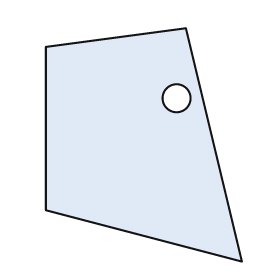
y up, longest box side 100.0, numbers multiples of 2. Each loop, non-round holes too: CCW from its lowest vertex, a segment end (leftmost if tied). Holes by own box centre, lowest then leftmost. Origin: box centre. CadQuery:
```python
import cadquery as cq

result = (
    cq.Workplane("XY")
    .moveTo(42.0, -50.0)
    .lineTo(18.0, 50.0)
    .lineTo(-42.0, 42.0)
    .lineTo(-42.0, -28.0)
    .close()
    .moveTo(14.0, 20.0)
    .circle(6.0)
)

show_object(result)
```